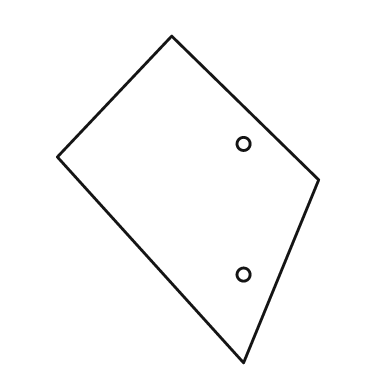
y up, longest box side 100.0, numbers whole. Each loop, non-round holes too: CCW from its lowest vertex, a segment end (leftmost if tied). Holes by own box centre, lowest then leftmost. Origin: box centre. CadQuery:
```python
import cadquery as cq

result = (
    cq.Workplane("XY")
    .moveTo(17.0, -50.0)
    .lineTo(40.0, 6.0)
    .lineTo(-5.0, 50.0)
    .lineTo(-40.0, 13.0)
    .close()
    .moveTo(17.0, -23.0)
    .circle(2.0)
    .moveTo(17.0, 17.0)
    .circle(2.0)
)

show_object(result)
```